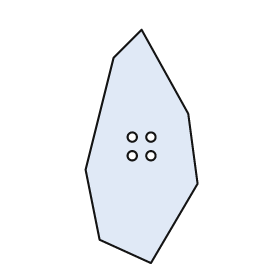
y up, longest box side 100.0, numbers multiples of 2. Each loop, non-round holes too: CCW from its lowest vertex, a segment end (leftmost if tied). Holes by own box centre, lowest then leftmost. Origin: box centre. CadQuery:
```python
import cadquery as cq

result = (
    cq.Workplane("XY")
    .moveTo(4.0, -50.0)
    .lineTo(24.0, -16.0)
    .lineTo(20.0, 14.0)
    .lineTo(0.0, 50.0)
    .lineTo(-12.0, 38.0)
    .lineTo(-24.0, -10.0)
    .lineTo(-18.0, -40.0)
    .close()
    .moveTo(-4.0, -4.0)
    .circle(2.0)
    .moveTo(4.0, -4.0)
    .circle(2.0)
    .moveTo(-4.0, 4.0)
    .circle(2.0)
    .moveTo(4.0, 4.0)
    .circle(2.0)
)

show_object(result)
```